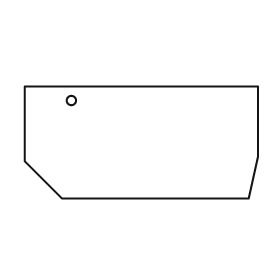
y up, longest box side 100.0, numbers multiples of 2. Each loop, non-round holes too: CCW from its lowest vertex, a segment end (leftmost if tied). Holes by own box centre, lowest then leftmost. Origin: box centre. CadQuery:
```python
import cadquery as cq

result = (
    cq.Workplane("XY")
    .moveTo(-34.0, -24.0)
    .lineTo(46.0, -24.0)
    .lineTo(50.0, -6.0)
    .lineTo(50.0, 24.0)
    .lineTo(-50.0, 24.0)
    .lineTo(-50.0, -8.0)
    .close()
    .moveTo(-30.0, 18.0)
    .circle(2.0)
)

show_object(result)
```